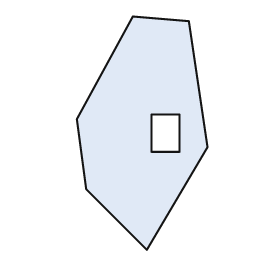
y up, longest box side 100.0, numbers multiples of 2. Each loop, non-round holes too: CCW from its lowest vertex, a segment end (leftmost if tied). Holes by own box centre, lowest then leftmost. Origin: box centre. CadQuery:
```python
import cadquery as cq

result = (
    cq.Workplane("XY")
    .moveTo(2.0, -50.0)
    .lineTo(28.0, -6.0)
    .lineTo(20.0, 48.0)
    .lineTo(-4.0, 50.0)
    .lineTo(-28.0, 6.0)
    .lineTo(-24.0, -24.0)
    .close()
    .moveTo(4.0, -8.0)
    .lineTo(16.0, -8.0)
    .lineTo(16.0, 8.0)
    .lineTo(4.0, 8.0)
    .close()
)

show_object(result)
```